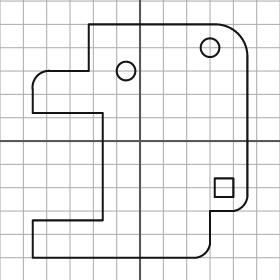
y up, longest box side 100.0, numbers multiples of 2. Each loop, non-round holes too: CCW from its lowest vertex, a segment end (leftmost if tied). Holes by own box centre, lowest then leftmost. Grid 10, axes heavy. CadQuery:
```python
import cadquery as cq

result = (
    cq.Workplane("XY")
    .moveTo(-46.0, -50.0)
    .lineTo(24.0, -50.0)
    .threePointArc((28.0, -48.0), (30.0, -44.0))
    .lineTo(30.0, -30.0)
    .lineTo(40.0, -30.0)
    .threePointArc((44.0, -28.0), (46.0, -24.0))
    .lineTo(46.0, 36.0)
    .threePointArc((42.0, 46.0), (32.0, 50.0))
    .lineTo(-22.0, 50.0)
    .lineTo(-22.0, 30.0)
    .lineTo(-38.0, 30.0)
    .threePointArc((-44.0, 28.0), (-46.0, 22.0))
    .lineTo(-46.0, 12.0)
    .lineTo(-16.0, 12.0)
    .lineTo(-16.0, -34.0)
    .lineTo(-46.0, -34.0)
    .close()
    .moveTo(32.0, -24.0)
    .lineTo(40.0, -24.0)
    .lineTo(40.0, -16.0)
    .lineTo(32.0, -16.0)
    .close()
    .moveTo(-6.0, 30.0)
    .circle(4.0)
    .moveTo(30.0, 40.0)
    .circle(4.0)
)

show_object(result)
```